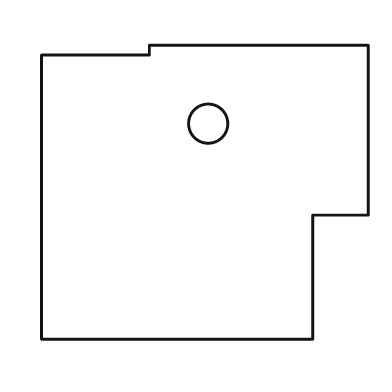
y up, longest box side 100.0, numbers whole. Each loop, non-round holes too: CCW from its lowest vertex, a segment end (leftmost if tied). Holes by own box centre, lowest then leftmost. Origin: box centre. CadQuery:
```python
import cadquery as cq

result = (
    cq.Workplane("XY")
    .moveTo(-50.0, -45.0)
    .lineTo(33.0, -45.0)
    .lineTo(33.0, -7.0)
    .lineTo(50.0, -7.0)
    .lineTo(50.0, 45.0)
    .lineTo(-17.0, 45.0)
    .lineTo(-17.0, 42.0)
    .lineTo(-50.0, 42.0)
    .close()
    .moveTo(1.0, 21.0)
    .circle(6.0)
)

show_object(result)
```